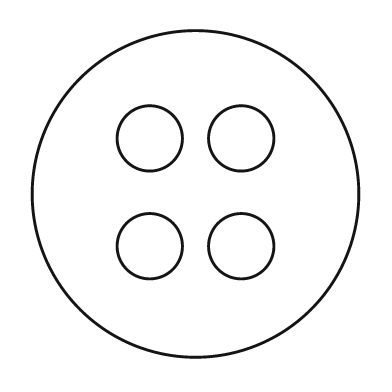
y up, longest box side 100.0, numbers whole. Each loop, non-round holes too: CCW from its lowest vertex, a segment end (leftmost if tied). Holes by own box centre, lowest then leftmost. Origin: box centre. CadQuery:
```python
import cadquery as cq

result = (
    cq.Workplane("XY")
    .moveTo(0.0, 0.0)
    .circle(50.0)
    .moveTo(-14.0, -16.0)
    .circle(10.0)
    .moveTo(14.0, -16.0)
    .circle(10.0)
    .moveTo(-14.0, 17.0)
    .circle(10.0)
    .moveTo(14.0, 17.0)
    .circle(10.0)
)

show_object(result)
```